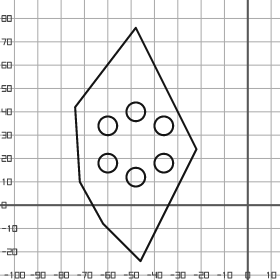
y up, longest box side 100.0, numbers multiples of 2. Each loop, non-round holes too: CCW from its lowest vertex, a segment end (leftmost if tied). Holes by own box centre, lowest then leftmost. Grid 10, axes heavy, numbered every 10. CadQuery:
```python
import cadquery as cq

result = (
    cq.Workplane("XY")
    .moveTo(-46.0, -24.0)
    .lineTo(-22.0, 24.0)
    .lineTo(-48.0, 76.0)
    .lineTo(-74.0, 42.0)
    .lineTo(-72.0, 10.0)
    .lineTo(-62.0, -8.0)
    .close()
    .moveTo(-48.0, 12.0)
    .circle(4.0)
    .moveTo(-60.0, 18.0)
    .circle(4.0)
    .moveTo(-36.0, 18.0)
    .circle(4.0)
    .moveTo(-60.0, 34.0)
    .circle(4.0)
    .moveTo(-36.0, 34.0)
    .circle(4.0)
    .moveTo(-48.0, 40.0)
    .circle(4.0)
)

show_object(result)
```